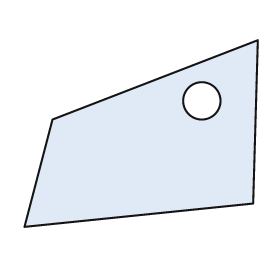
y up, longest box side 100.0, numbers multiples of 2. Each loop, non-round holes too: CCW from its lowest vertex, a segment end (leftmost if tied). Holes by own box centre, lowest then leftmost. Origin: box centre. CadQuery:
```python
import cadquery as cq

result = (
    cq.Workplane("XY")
    .moveTo(-50.0, -40.0)
    .lineTo(48.0, -30.0)
    .lineTo(50.0, 40.0)
    .lineTo(-38.0, 6.0)
    .close()
    .moveTo(26.0, 14.0)
    .circle(8.0)
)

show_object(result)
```